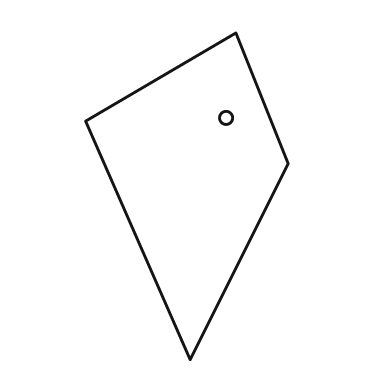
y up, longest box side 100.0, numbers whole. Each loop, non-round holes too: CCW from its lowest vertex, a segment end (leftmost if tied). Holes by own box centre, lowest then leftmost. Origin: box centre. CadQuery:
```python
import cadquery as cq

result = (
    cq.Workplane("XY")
    .moveTo(1.0, -50.0)
    .lineTo(31.0, 10.0)
    .lineTo(15.0, 50.0)
    .lineTo(-31.0, 23.0)
    .close()
    .moveTo(12.0, 24.0)
    .circle(2.0)
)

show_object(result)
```